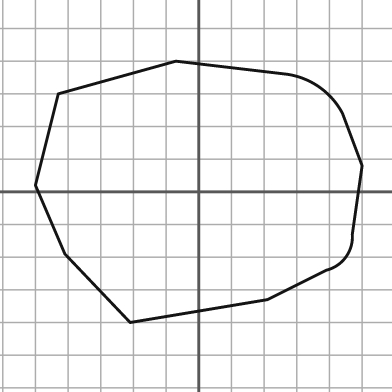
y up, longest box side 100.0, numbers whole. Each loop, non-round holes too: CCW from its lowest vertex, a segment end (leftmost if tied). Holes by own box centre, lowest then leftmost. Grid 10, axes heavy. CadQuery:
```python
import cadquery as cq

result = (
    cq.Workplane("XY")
    .moveTo(-21.0, -40.0)
    .lineTo(21.0, -33.0)
    .lineTo(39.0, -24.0)
    .threePointArc((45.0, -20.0), (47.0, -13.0))
    .lineTo(50.0, 8.0)
    .lineTo(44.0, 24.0)
    .threePointArc((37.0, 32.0), (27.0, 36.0))
    .lineTo(-7.0, 40.0)
    .lineTo(-43.0, 30.0)
    .lineTo(-50.0, 2.0)
    .lineTo(-41.0, -19.0)
    .close()
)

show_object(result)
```